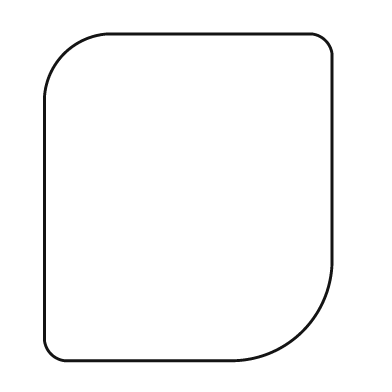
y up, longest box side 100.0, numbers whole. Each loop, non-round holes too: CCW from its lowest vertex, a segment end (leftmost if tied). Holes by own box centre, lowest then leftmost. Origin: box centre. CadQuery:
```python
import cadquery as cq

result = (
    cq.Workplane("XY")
    .moveTo(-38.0, -50.0)
    .lineTo(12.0, -50.0)
    .threePointArc((35.0, -41.0), (44.0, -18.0))
    .lineTo(44.0, 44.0)
    .threePointArc((42.0, 48.0), (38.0, 50.0))
    .lineTo(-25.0, 50.0)
    .threePointArc((-38.0, 44.0), (-44.0, 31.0))
    .lineTo(-44.0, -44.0)
    .threePointArc((-42.0, -48.0), (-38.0, -50.0))
    .close()
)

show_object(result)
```